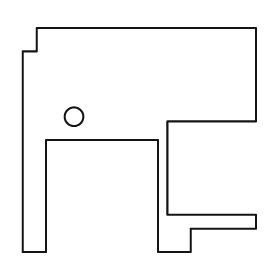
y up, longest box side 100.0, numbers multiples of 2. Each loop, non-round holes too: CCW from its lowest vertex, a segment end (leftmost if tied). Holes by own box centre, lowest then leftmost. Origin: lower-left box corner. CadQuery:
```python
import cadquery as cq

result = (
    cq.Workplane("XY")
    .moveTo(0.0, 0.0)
    .lineTo(10.0, 0.0)
    .lineTo(10.0, 48.0)
    .lineTo(58.0, 48.0)
    .lineTo(58.0, 0.0)
    .lineTo(72.0, 0.0)
    .lineTo(72.0, 10.0)
    .lineTo(100.0, 10.0)
    .lineTo(100.0, 16.0)
    .lineTo(62.0, 16.0)
    .lineTo(62.0, 56.0)
    .lineTo(100.0, 56.0)
    .lineTo(100.0, 96.0)
    .lineTo(6.0, 96.0)
    .lineTo(6.0, 86.0)
    .lineTo(0.0, 86.0)
    .close()
    .moveTo(22.0, 58.0)
    .circle(4.0)
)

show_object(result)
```